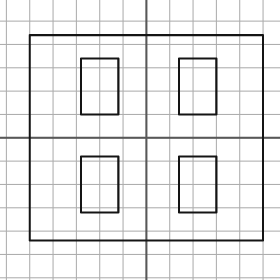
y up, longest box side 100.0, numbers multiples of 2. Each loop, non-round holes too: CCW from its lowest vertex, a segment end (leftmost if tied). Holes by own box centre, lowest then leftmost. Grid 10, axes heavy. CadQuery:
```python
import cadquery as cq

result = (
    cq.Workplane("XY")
    .moveTo(-50.0, -44.0)
    .lineTo(50.0, -44.0)
    .lineTo(50.0, 44.0)
    .lineTo(-50.0, 44.0)
    .close()
    .moveTo(-28.0, -32.0)
    .lineTo(-12.0, -32.0)
    .lineTo(-12.0, -8.0)
    .lineTo(-28.0, -8.0)
    .close()
    .moveTo(14.0, -32.0)
    .lineTo(30.0, -32.0)
    .lineTo(30.0, -8.0)
    .lineTo(14.0, -8.0)
    .close()
    .moveTo(-28.0, 10.0)
    .lineTo(-12.0, 10.0)
    .lineTo(-12.0, 34.0)
    .lineTo(-28.0, 34.0)
    .close()
    .moveTo(14.0, 10.0)
    .lineTo(30.0, 10.0)
    .lineTo(30.0, 34.0)
    .lineTo(14.0, 34.0)
    .close()
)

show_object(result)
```